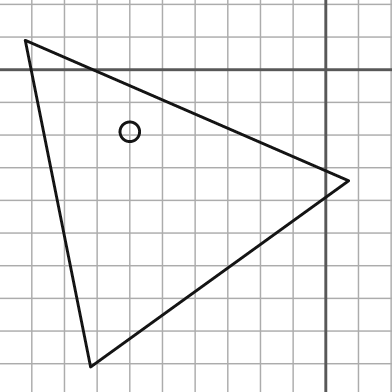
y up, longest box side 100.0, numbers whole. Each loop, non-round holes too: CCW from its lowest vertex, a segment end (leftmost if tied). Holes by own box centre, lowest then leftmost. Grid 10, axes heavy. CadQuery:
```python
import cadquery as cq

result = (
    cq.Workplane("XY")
    .moveTo(-72.0, -91.0)
    .lineTo(7.0, -34.0)
    .lineTo(-92.0, 9.0)
    .close()
    .moveTo(-60.0, -19.0)
    .circle(3.0)
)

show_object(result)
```